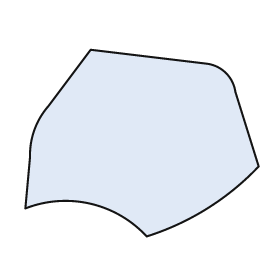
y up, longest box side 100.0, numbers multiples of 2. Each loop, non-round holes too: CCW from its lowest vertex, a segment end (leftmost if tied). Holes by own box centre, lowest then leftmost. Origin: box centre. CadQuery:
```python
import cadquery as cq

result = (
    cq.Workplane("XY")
    .moveTo(2.0, -40.0)
    .threePointArc((28.0, -28.0), (50.0, -10.0))
    .lineTo(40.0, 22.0)
    .threePointArc((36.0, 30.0), (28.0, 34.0))
    .lineTo(-22.0, 40.0)
    .lineTo(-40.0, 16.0)
    .threePointArc((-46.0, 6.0), (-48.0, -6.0))
    .lineTo(-50.0, -28.0)
    .threePointArc((-22.0, -26.0), (2.0, -40.0))
    .close()
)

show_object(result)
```